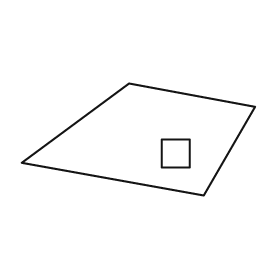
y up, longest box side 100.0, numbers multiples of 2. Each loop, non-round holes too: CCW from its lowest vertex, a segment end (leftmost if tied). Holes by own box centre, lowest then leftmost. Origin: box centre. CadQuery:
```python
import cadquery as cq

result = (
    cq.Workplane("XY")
    .moveTo(28.0, -24.0)
    .lineTo(50.0, 14.0)
    .lineTo(-4.0, 24.0)
    .lineTo(-50.0, -10.0)
    .close()
    .moveTo(10.0, -12.0)
    .lineTo(22.0, -12.0)
    .lineTo(22.0, 0.0)
    .lineTo(10.0, 0.0)
    .close()
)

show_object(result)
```